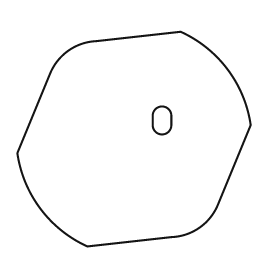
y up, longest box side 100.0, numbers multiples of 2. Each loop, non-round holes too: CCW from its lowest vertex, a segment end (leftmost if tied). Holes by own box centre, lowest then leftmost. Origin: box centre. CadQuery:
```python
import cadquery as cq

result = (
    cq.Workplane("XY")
    .moveTo(-20.0, -46.0)
    .lineTo(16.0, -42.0)
    .threePointArc((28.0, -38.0), (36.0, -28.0))
    .lineTo(50.0, 6.0)
    .threePointArc((40.0, 30.0), (20.0, 46.0))
    .lineTo(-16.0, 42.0)
    .threePointArc((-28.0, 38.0), (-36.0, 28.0))
    .lineTo(-50.0, -6.0)
    .threePointArc((-40.0, -30.0), (-20.0, -46.0))
    .close()
    .moveTo(8.0, 6.0)
    .threePointArc((12.0, 2.0), (16.0, 6.0))
    .lineTo(16.0, 10.0)
    .threePointArc((12.0, 14.0), (8.0, 10.0))
    .close()
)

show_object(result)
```